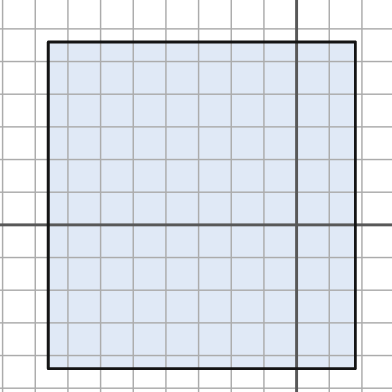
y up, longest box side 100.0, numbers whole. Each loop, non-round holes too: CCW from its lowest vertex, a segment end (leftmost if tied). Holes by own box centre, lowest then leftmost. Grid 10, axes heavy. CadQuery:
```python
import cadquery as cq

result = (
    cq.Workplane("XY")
    .moveTo(-76.0, -44.0)
    .lineTo(18.0, -44.0)
    .lineTo(18.0, 56.0)
    .lineTo(-76.0, 56.0)
    .close()
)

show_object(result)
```